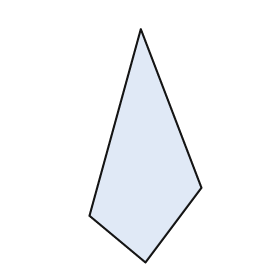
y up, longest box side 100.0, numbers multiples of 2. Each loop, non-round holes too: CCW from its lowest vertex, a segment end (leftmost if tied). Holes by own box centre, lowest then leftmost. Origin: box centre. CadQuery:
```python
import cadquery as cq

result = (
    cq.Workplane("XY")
    .moveTo(0.0, -50.0)
    .lineTo(24.0, -18.0)
    .lineTo(-2.0, 50.0)
    .lineTo(-24.0, -30.0)
    .close()
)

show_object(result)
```